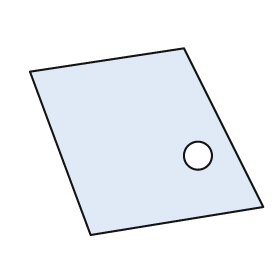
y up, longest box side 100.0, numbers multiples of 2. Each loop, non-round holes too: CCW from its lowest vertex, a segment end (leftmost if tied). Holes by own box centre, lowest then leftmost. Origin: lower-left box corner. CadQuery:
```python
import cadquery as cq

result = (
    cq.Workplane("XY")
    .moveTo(26.0, 0.0)
    .lineTo(100.0, 12.0)
    .lineTo(66.0, 80.0)
    .lineTo(0.0, 70.0)
    .close()
    .moveTo(72.0, 34.0)
    .circle(6.0)
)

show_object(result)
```